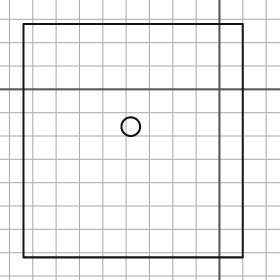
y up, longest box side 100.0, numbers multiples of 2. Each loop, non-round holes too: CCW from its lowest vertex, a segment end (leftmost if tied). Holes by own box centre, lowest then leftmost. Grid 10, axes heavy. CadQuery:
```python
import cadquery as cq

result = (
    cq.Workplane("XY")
    .moveTo(-84.0, -72.0)
    .lineTo(10.0, -72.0)
    .lineTo(10.0, 28.0)
    .lineTo(-84.0, 28.0)
    .close()
    .moveTo(-38.0, -16.0)
    .circle(4.0)
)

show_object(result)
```